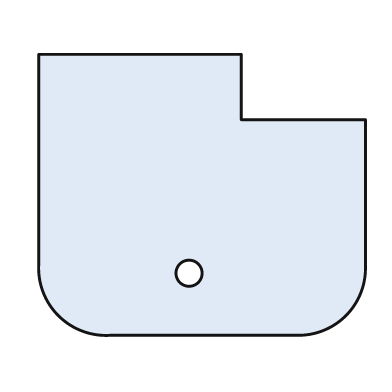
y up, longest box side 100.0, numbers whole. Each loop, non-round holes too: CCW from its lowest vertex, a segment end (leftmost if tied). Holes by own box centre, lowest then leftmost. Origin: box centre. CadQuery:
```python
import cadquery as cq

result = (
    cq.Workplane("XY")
    .moveTo(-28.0, -43.0)
    .lineTo(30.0, -43.0)
    .threePointArc((44.0, -37.0), (50.0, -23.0))
    .lineTo(50.0, 23.0)
    .lineTo(12.0, 23.0)
    .lineTo(12.0, 43.0)
    .lineTo(-50.0, 43.0)
    .lineTo(-50.0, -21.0)
    .threePointArc((-44.0, -37.0), (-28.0, -43.0))
    .close()
    .moveTo(-4.0, -24.0)
    .circle(4.0)
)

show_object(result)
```